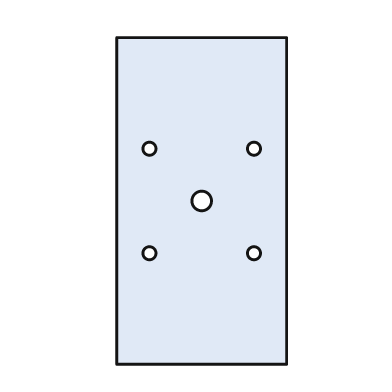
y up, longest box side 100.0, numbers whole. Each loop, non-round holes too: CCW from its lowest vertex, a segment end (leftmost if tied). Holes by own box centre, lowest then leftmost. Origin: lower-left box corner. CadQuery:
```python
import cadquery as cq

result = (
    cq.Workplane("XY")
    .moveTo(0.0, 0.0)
    .lineTo(52.0, 0.0)
    .lineTo(52.0, 100.0)
    .lineTo(0.0, 100.0)
    .close()
    .moveTo(10.0, 34.0)
    .circle(2.0)
    .moveTo(42.0, 34.0)
    .circle(2.0)
    .moveTo(26.0, 50.0)
    .circle(3.0)
    .moveTo(10.0, 66.0)
    .circle(2.0)
    .moveTo(42.0, 66.0)
    .circle(2.0)
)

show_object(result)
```